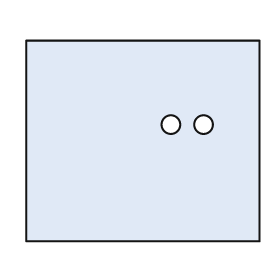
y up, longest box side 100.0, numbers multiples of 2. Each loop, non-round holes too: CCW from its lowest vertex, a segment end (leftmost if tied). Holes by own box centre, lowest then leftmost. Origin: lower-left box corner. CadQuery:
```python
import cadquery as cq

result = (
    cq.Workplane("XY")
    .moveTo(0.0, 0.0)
    .lineTo(100.0, 0.0)
    .lineTo(100.0, 86.0)
    .lineTo(0.0, 86.0)
    .close()
    .moveTo(62.0, 50.0)
    .circle(4.0)
    .moveTo(76.0, 50.0)
    .circle(4.0)
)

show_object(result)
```